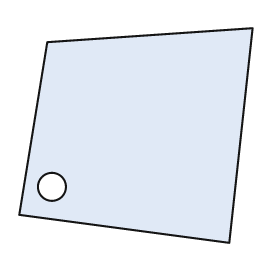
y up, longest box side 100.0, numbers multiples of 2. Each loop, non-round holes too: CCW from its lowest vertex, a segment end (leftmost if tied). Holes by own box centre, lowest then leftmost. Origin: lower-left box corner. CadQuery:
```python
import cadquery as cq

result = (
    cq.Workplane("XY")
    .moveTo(90.0, 0.0)
    .lineTo(100.0, 92.0)
    .lineTo(12.0, 86.0)
    .lineTo(0.0, 12.0)
    .close()
    .moveTo(14.0, 24.0)
    .circle(6.0)
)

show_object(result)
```